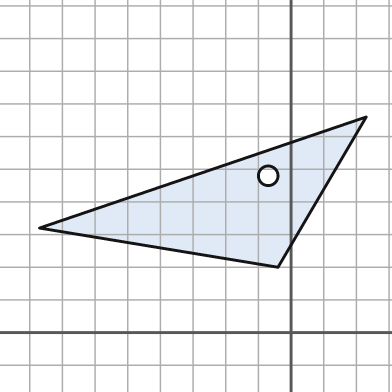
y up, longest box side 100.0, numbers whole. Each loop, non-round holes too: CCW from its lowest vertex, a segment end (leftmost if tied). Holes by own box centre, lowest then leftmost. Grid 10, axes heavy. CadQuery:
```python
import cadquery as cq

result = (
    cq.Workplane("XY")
    .moveTo(-4.0, 20.0)
    .lineTo(23.0, 66.0)
    .lineTo(-77.0, 32.0)
    .close()
    .moveTo(-7.0, 48.0)
    .circle(3.0)
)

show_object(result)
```